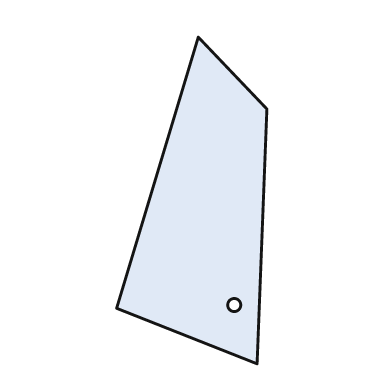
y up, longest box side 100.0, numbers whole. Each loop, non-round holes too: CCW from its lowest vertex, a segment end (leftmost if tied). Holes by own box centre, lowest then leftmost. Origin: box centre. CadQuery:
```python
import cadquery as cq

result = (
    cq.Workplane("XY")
    .moveTo(20.0, -50.0)
    .lineTo(23.0, 28.0)
    .lineTo(2.0, 50.0)
    .lineTo(-23.0, -33.0)
    .close()
    .moveTo(13.0, -32.0)
    .circle(2.0)
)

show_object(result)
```